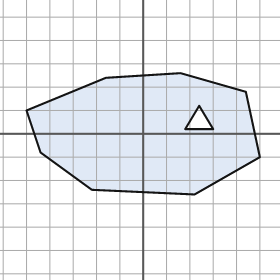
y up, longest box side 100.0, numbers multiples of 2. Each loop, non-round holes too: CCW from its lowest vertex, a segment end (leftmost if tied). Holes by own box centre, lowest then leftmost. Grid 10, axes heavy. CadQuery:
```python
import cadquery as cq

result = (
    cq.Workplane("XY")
    .moveTo(22.0, -26.0)
    .lineTo(50.0, -10.0)
    .lineTo(44.0, 18.0)
    .lineTo(16.0, 26.0)
    .lineTo(-16.0, 24.0)
    .lineTo(-50.0, 10.0)
    .lineTo(-44.0, -8.0)
    .lineTo(-22.0, -24.0)
    .close()
    .moveTo(18.0, 2.0)
    .lineTo(30.0, 2.0)
    .lineTo(24.0, 12.0)
    .close()
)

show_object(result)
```